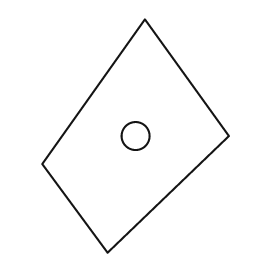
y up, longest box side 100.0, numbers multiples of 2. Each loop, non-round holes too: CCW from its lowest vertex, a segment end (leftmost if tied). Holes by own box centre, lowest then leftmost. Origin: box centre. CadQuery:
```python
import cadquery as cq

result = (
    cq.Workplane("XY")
    .moveTo(-12.0, -50.0)
    .lineTo(40.0, 0.0)
    .lineTo(4.0, 50.0)
    .lineTo(-40.0, -12.0)
    .close()
    .moveTo(0.0, 0.0)
    .circle(6.0)
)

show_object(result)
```